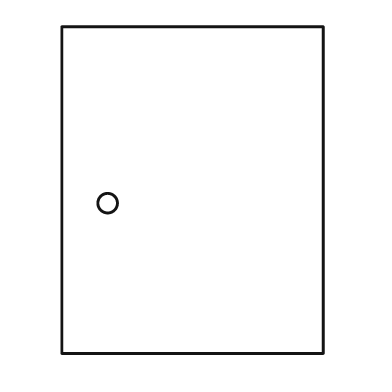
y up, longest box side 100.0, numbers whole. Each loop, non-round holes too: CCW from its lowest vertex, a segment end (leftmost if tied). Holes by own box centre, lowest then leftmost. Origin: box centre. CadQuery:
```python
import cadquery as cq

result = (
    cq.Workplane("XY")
    .moveTo(-40.0, -50.0)
    .lineTo(40.0, -50.0)
    .lineTo(40.0, 50.0)
    .lineTo(-40.0, 50.0)
    .close()
    .moveTo(-26.0, -4.0)
    .circle(3.0)
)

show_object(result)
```